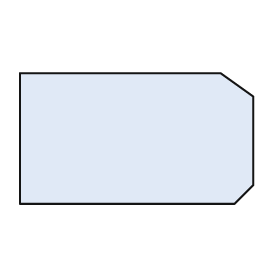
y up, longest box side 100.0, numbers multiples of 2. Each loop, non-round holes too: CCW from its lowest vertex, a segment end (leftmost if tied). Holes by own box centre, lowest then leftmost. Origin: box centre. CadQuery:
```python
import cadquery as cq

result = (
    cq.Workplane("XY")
    .moveTo(-50.0, -28.0)
    .lineTo(42.0, -28.0)
    .lineTo(50.0, -20.0)
    .lineTo(50.0, 18.0)
    .lineTo(36.0, 28.0)
    .lineTo(-50.0, 28.0)
    .close()
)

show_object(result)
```